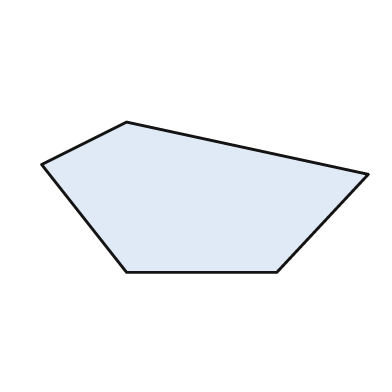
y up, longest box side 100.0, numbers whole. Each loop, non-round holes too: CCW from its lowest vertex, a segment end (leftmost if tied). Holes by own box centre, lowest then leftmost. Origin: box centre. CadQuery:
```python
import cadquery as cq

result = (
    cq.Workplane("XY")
    .moveTo(-24.0, -23.0)
    .lineTo(22.0, -23.0)
    .lineTo(50.0, 7.0)
    .lineTo(-24.0, 23.0)
    .lineTo(-50.0, 10.0)
    .close()
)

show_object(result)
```